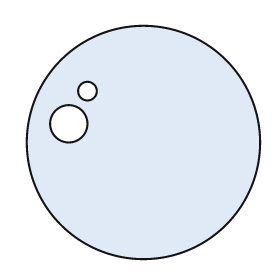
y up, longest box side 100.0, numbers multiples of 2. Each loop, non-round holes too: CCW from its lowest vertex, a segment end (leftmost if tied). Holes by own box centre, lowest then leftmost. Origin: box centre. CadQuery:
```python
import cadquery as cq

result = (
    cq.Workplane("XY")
    .moveTo(0.0, 0.0)
    .circle(50.0)
    .moveTo(-32.0, 8.0)
    .circle(8.0)
    .moveTo(-24.0, 22.0)
    .circle(4.0)
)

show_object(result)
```